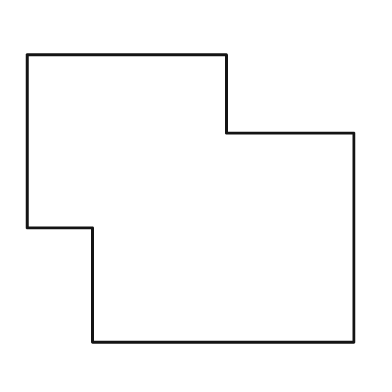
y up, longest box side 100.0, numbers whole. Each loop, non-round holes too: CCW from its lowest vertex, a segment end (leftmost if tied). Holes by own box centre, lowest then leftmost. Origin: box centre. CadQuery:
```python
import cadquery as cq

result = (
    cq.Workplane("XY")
    .moveTo(-30.0, -44.0)
    .lineTo(50.0, -44.0)
    .lineTo(50.0, 20.0)
    .lineTo(11.0, 20.0)
    .lineTo(11.0, 44.0)
    .lineTo(-50.0, 44.0)
    .lineTo(-50.0, -9.0)
    .lineTo(-30.0, -9.0)
    .close()
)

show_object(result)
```